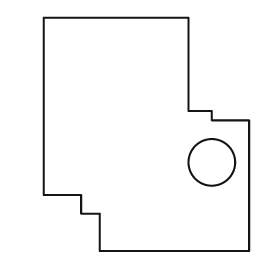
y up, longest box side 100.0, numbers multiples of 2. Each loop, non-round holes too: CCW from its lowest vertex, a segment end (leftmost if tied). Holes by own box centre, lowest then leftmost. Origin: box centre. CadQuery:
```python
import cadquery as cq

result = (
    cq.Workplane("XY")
    .moveTo(-20.0, -50.0)
    .lineTo(44.0, -50.0)
    .lineTo(44.0, 6.0)
    .lineTo(28.0, 6.0)
    .lineTo(28.0, 10.0)
    .lineTo(18.0, 10.0)
    .lineTo(18.0, 50.0)
    .lineTo(-44.0, 50.0)
    .lineTo(-44.0, -26.0)
    .lineTo(-28.0, -26.0)
    .lineTo(-28.0, -34.0)
    .lineTo(-20.0, -34.0)
    .close()
    .moveTo(28.0, -12.0)
    .circle(10.0)
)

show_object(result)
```